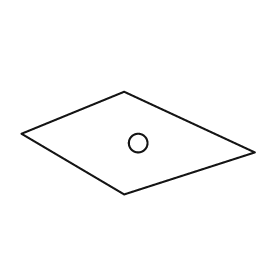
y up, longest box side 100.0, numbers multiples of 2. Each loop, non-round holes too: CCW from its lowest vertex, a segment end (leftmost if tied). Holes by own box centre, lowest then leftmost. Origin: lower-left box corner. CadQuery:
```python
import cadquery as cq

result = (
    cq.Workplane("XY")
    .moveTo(44.0, 0.0)
    .lineTo(100.0, 18.0)
    .lineTo(44.0, 44.0)
    .lineTo(0.0, 26.0)
    .close()
    .moveTo(50.0, 22.0)
    .circle(4.0)
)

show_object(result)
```